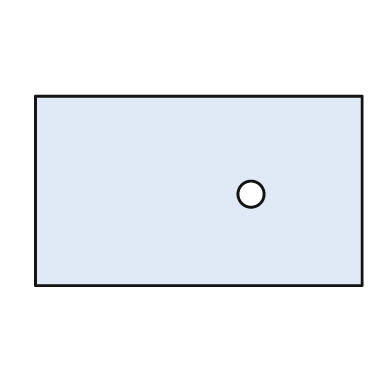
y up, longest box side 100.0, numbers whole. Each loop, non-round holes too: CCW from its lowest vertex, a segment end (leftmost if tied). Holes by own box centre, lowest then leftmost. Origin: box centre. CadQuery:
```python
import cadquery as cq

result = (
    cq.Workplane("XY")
    .moveTo(-50.0, -29.0)
    .lineTo(50.0, -29.0)
    .lineTo(50.0, 29.0)
    .lineTo(-50.0, 29.0)
    .close()
    .moveTo(16.0, -1.0)
    .circle(4.0)
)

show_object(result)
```